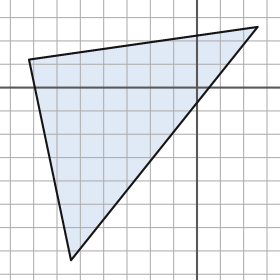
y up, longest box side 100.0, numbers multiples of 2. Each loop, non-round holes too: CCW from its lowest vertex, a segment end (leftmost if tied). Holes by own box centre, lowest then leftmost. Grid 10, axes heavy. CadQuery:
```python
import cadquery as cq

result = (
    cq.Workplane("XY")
    .moveTo(-54.0, -74.0)
    .lineTo(26.0, 26.0)
    .lineTo(-72.0, 12.0)
    .close()
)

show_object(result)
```